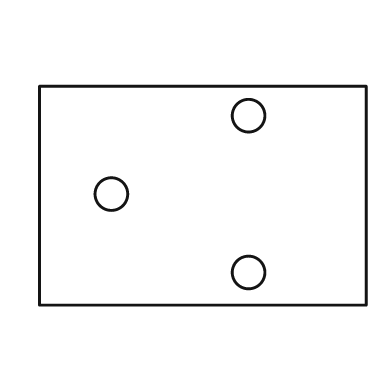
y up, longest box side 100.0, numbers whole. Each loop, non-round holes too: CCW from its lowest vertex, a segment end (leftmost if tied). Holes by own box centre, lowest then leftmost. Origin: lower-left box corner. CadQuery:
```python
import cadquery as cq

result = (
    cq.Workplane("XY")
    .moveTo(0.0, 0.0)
    .lineTo(100.0, 0.0)
    .lineTo(100.0, 67.0)
    .lineTo(0.0, 67.0)
    .close()
    .moveTo(64.0, 10.0)
    .circle(5.0)
    .moveTo(22.0, 34.0)
    .circle(5.0)
    .moveTo(64.0, 58.0)
    .circle(5.0)
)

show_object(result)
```